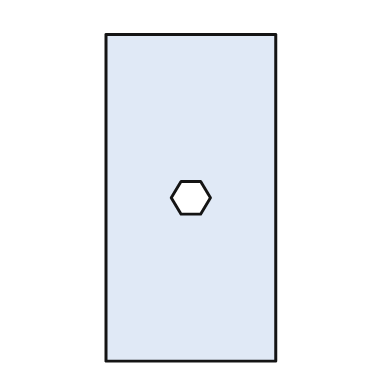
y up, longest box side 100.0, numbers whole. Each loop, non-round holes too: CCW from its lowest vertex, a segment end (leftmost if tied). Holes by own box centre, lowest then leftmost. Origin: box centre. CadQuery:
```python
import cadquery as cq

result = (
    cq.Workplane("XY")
    .moveTo(-26.0, -50.0)
    .lineTo(26.0, -50.0)
    .lineTo(26.0, 50.0)
    .lineTo(-26.0, 50.0)
    .close()
    .moveTo(-3.0, -5.0)
    .lineTo(3.0, -5.0)
    .lineTo(6.0, 0.0)
    .lineTo(3.0, 5.0)
    .lineTo(-3.0, 5.0)
    .lineTo(-6.0, 0.0)
    .close()
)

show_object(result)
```